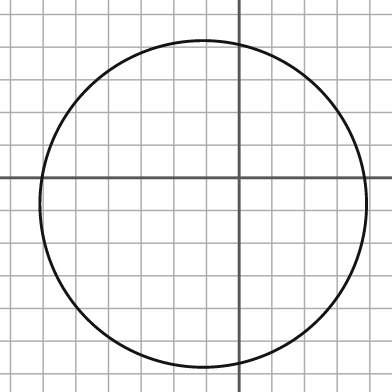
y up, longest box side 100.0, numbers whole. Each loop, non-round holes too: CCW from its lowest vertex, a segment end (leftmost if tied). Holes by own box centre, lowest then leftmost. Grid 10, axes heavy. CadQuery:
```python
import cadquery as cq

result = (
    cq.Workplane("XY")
    .moveTo(-11.0, -8.0)
    .circle(50.0)
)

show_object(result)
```